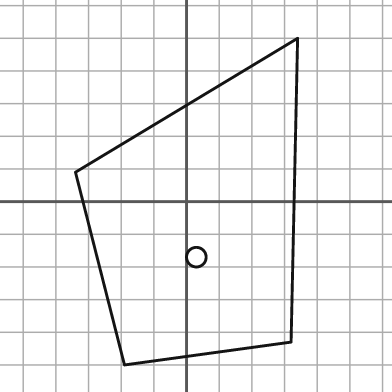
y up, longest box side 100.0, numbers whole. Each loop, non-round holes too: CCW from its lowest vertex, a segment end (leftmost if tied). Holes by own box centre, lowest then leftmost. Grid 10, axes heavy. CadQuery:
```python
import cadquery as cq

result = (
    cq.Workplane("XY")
    .moveTo(-19.0, -50.0)
    .lineTo(32.0, -43.0)
    .lineTo(34.0, 50.0)
    .lineTo(-34.0, 9.0)
    .close()
    .moveTo(3.0, -17.0)
    .circle(3.0)
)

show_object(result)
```